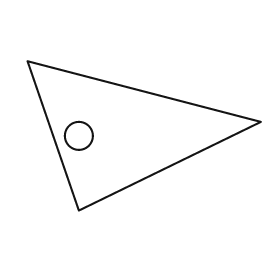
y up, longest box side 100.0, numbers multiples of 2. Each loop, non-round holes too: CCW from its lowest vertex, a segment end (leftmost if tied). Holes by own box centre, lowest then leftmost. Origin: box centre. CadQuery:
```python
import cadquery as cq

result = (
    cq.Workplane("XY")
    .moveTo(-28.0, -32.0)
    .lineTo(50.0, 6.0)
    .lineTo(-50.0, 32.0)
    .close()
    .moveTo(-28.0, 0.0)
    .circle(6.0)
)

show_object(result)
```